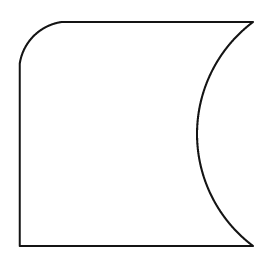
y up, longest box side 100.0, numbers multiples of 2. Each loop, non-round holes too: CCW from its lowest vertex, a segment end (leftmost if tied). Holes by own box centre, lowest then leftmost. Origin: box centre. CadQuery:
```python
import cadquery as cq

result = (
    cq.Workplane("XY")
    .moveTo(-50.0, -48.0)
    .lineTo(50.0, -48.0)
    .threePointArc((26.0, 0.0), (50.0, 48.0))
    .lineTo(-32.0, 48.0)
    .threePointArc((-44.0, 42.0), (-50.0, 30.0))
    .close()
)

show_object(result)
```